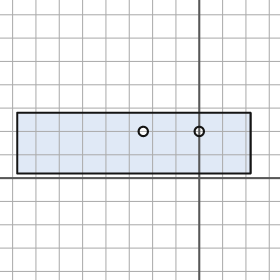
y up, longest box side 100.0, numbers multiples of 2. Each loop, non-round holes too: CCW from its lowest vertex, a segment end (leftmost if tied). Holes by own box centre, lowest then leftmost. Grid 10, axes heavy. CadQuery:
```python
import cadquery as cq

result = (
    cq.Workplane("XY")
    .moveTo(-78.0, 2.0)
    .lineTo(22.0, 2.0)
    .lineTo(22.0, 28.0)
    .lineTo(-78.0, 28.0)
    .close()
    .moveTo(-24.0, 20.0)
    .circle(2.0)
    .moveTo(0.0, 20.0)
    .circle(2.0)
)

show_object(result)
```